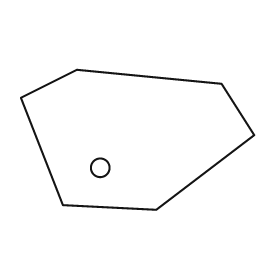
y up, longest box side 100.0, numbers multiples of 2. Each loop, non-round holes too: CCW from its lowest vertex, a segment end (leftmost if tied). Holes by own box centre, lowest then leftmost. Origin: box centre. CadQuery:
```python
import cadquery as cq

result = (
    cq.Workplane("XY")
    .moveTo(8.0, -30.0)
    .lineTo(50.0, 2.0)
    .lineTo(36.0, 24.0)
    .lineTo(-26.0, 30.0)
    .lineTo(-50.0, 18.0)
    .lineTo(-32.0, -28.0)
    .close()
    .moveTo(-16.0, -12.0)
    .circle(4.0)
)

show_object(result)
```